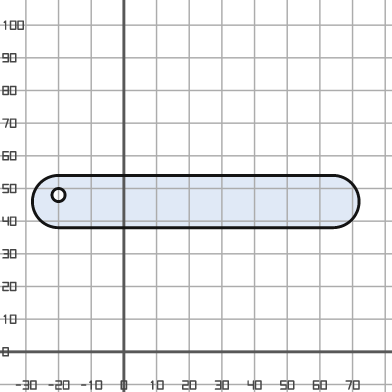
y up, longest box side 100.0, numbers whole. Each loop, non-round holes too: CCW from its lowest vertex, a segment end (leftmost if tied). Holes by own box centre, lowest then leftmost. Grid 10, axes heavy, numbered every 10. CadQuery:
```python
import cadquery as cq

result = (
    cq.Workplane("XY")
    .moveTo(-20.0, 38.0)
    .lineTo(64.0, 38.0)
    .threePointArc((72.0, 46.0), (64.0, 54.0))
    .lineTo(-20.0, 54.0)
    .threePointArc((-28.0, 46.0), (-20.0, 38.0))
    .close()
    .moveTo(-20.0, 48.0)
    .circle(2.0)
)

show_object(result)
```